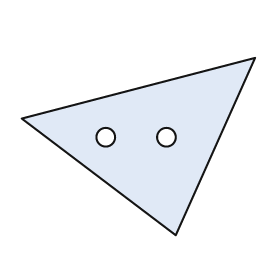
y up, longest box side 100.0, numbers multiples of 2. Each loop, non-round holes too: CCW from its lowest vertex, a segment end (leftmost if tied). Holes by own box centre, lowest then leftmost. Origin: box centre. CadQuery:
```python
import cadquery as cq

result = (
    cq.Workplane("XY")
    .moveTo(16.0, -38.0)
    .lineTo(50.0, 38.0)
    .lineTo(-50.0, 12.0)
    .close()
    .moveTo(-14.0, 4.0)
    .circle(4.0)
    .moveTo(12.0, 4.0)
    .circle(4.0)
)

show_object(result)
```